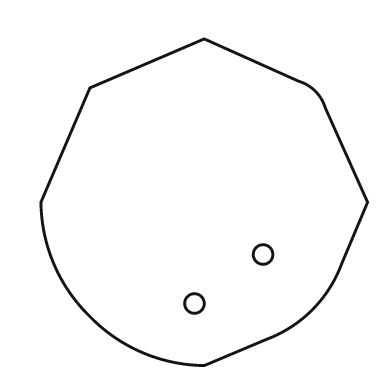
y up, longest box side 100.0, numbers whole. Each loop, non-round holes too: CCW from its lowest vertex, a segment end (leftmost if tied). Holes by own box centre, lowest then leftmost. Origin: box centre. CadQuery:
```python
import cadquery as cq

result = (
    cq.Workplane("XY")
    .moveTo(0.0, -50.0)
    .lineTo(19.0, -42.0)
    .threePointArc((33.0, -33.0), (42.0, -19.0))
    .lineTo(50.0, 0.0)
    .lineTo(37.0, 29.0)
    .threePointArc((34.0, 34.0), (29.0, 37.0))
    .lineTo(0.0, 50.0)
    .lineTo(-35.0, 35.0)
    .lineTo(-50.0, 0.0)
    .threePointArc((-46.0, -19.0), (-35.0, -35.0))
    .threePointArc((-19.0, -46.0), (0.0, -50.0))
    .close()
    .moveTo(-3.0, -31.0)
    .circle(3.0)
    .moveTo(18.0, -16.0)
    .circle(3.0)
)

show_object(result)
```